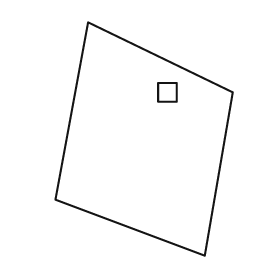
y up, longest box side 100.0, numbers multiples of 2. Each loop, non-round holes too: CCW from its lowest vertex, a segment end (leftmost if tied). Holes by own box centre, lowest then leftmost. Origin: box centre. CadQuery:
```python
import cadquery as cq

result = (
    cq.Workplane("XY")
    .moveTo(26.0, -50.0)
    .lineTo(38.0, 20.0)
    .lineTo(-24.0, 50.0)
    .lineTo(-38.0, -26.0)
    .close()
    .moveTo(6.0, 16.0)
    .lineTo(14.0, 16.0)
    .lineTo(14.0, 24.0)
    .lineTo(6.0, 24.0)
    .close()
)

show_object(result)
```